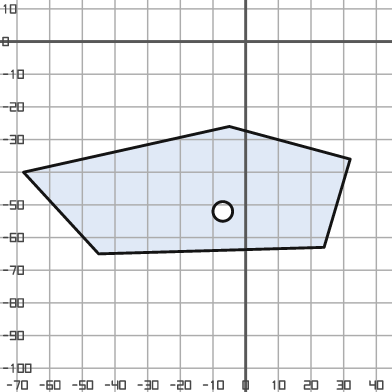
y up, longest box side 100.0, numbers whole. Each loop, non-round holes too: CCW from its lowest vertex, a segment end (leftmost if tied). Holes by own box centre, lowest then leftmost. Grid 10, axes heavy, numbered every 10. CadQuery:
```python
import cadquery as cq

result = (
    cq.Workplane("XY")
    .moveTo(-45.0, -65.0)
    .lineTo(24.0, -63.0)
    .lineTo(32.0, -36.0)
    .lineTo(-5.0, -26.0)
    .lineTo(-68.0, -40.0)
    .close()
    .moveTo(-7.0, -52.0)
    .circle(3.0)
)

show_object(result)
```